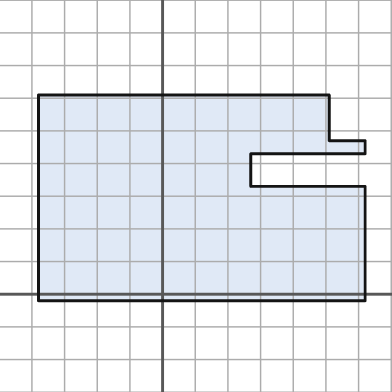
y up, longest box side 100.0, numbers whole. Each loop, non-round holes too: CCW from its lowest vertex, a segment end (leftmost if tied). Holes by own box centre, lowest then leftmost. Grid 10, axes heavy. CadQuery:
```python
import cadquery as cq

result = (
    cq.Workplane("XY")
    .moveTo(-38.0, -2.0)
    .lineTo(62.0, -2.0)
    .lineTo(62.0, 33.0)
    .lineTo(27.0, 33.0)
    .lineTo(27.0, 43.0)
    .lineTo(62.0, 43.0)
    .lineTo(62.0, 47.0)
    .lineTo(51.0, 47.0)
    .lineTo(51.0, 61.0)
    .lineTo(-38.0, 61.0)
    .close()
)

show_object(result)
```